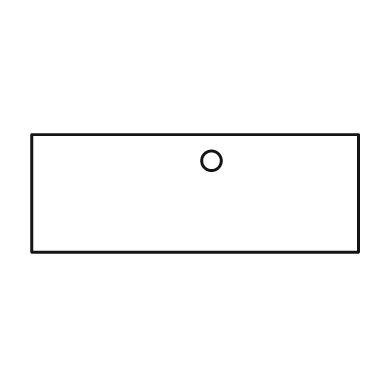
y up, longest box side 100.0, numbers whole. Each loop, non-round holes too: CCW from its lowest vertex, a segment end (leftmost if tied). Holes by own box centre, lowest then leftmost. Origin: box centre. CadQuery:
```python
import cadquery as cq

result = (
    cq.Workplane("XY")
    .moveTo(-50.0, -18.0)
    .lineTo(50.0, -18.0)
    .lineTo(50.0, 18.0)
    .lineTo(-50.0, 18.0)
    .close()
    .moveTo(5.0, 10.0)
    .circle(3.0)
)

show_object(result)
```